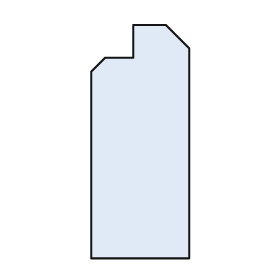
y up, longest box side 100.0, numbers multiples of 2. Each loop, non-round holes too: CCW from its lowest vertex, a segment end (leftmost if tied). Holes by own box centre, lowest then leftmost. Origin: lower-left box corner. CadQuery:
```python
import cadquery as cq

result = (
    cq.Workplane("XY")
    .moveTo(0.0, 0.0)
    .lineTo(42.0, 0.0)
    .lineTo(42.0, 90.0)
    .lineTo(32.0, 100.0)
    .lineTo(18.0, 100.0)
    .lineTo(18.0, 86.0)
    .lineTo(6.0, 86.0)
    .lineTo(0.0, 80.0)
    .close()
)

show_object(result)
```